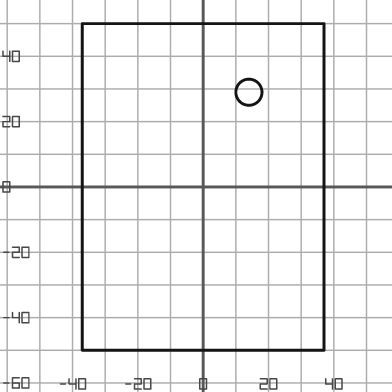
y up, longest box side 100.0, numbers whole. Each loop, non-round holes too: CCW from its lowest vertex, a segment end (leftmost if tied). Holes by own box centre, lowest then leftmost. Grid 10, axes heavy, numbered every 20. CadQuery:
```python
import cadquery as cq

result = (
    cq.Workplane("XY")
    .moveTo(-37.0, -50.0)
    .lineTo(37.0, -50.0)
    .lineTo(37.0, 50.0)
    .lineTo(-37.0, 50.0)
    .close()
    .moveTo(14.0, 29.0)
    .circle(4.0)
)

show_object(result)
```